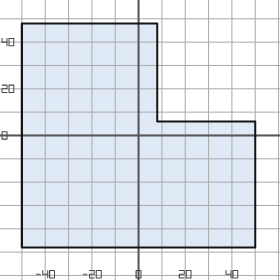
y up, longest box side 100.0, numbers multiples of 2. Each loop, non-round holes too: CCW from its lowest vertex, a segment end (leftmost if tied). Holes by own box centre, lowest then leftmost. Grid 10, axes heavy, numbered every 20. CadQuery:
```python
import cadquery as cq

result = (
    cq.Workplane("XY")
    .moveTo(-50.0, -48.0)
    .lineTo(50.0, -48.0)
    .lineTo(50.0, 6.0)
    .lineTo(8.0, 6.0)
    .lineTo(8.0, 48.0)
    .lineTo(-50.0, 48.0)
    .close()
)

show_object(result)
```